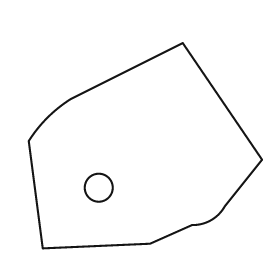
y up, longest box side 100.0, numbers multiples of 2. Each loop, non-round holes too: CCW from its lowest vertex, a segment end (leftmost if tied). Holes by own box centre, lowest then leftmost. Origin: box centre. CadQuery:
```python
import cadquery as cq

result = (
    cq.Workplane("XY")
    .moveTo(-44.0, -44.0)
    .lineTo(2.0, -42.0)
    .lineTo(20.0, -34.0)
    .threePointArc((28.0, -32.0), (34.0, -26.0))
    .lineTo(50.0, -6.0)
    .lineTo(16.0, 44.0)
    .lineTo(-32.0, 20.0)
    .threePointArc((-42.0, 12.0), (-50.0, 2.0))
    .close()
    .moveTo(-20.0, -18.0)
    .circle(6.0)
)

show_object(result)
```